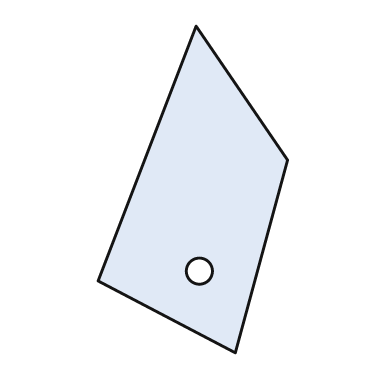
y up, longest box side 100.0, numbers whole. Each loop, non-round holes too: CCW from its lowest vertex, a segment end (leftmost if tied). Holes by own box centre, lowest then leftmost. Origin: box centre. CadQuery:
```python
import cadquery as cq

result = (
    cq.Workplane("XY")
    .moveTo(13.0, -50.0)
    .lineTo(29.0, 9.0)
    .lineTo(1.0, 50.0)
    .lineTo(-29.0, -28.0)
    .close()
    .moveTo(2.0, -25.0)
    .circle(4.0)
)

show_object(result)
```